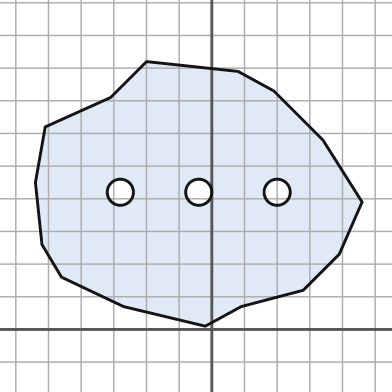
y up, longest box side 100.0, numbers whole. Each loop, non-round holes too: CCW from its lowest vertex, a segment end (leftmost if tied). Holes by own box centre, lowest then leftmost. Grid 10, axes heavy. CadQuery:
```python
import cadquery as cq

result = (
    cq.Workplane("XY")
    .moveTo(-2.0, 1.0)
    .lineTo(9.0, 7.0)
    .lineTo(28.0, 12.0)
    .lineTo(39.0, 23.0)
    .lineTo(46.0, 39.0)
    .lineTo(34.0, 58.0)
    .lineTo(19.0, 73.0)
    .lineTo(8.0, 79.0)
    .lineTo(-20.0, 82.0)
    .lineTo(-31.0, 71.0)
    .lineTo(-51.0, 62.0)
    .lineTo(-54.0, 45.0)
    .lineTo(-52.0, 26.0)
    .lineTo(-46.0, 16.0)
    .lineTo(-27.0, 7.0)
    .close()
    .moveTo(-28.0, 42.0)
    .circle(4.0)
    .moveTo(-4.0, 42.0)
    .circle(4.0)
    .moveTo(20.0, 42.0)
    .circle(4.0)
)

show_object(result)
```